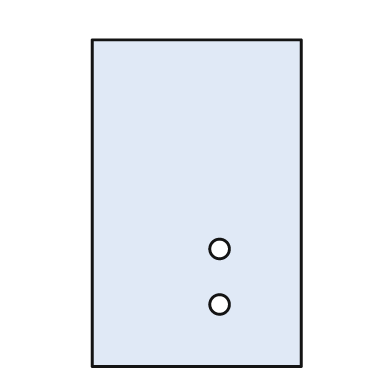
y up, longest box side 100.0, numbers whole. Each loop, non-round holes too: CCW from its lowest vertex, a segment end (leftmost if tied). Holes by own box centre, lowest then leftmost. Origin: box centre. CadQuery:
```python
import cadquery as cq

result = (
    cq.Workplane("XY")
    .moveTo(-32.0, -50.0)
    .lineTo(32.0, -50.0)
    .lineTo(32.0, 50.0)
    .lineTo(-32.0, 50.0)
    .close()
    .moveTo(7.0, -31.0)
    .circle(3.0)
    .moveTo(7.0, -14.0)
    .circle(3.0)
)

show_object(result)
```